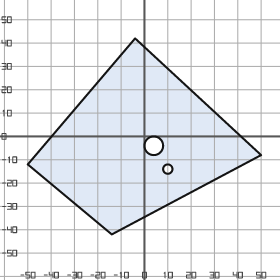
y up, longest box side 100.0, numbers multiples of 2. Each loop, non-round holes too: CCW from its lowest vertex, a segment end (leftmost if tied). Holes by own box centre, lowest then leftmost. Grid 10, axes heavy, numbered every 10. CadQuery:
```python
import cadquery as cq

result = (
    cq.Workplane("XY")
    .moveTo(-14.0, -42.0)
    .lineTo(50.0, -8.0)
    .lineTo(-4.0, 42.0)
    .lineTo(-50.0, -12.0)
    .close()
    .moveTo(10.0, -14.0)
    .circle(2.0)
    .moveTo(4.0, -4.0)
    .circle(4.0)
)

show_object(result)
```